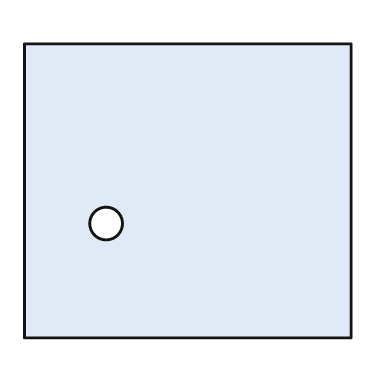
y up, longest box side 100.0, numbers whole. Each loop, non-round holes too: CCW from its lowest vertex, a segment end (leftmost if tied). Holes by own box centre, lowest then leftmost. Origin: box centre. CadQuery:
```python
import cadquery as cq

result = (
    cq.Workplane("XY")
    .moveTo(-50.0, -45.0)
    .lineTo(50.0, -45.0)
    .lineTo(50.0, 45.0)
    .lineTo(-50.0, 45.0)
    .close()
    .moveTo(-25.0, -10.0)
    .circle(5.0)
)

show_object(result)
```